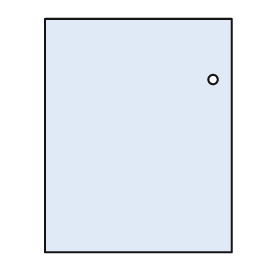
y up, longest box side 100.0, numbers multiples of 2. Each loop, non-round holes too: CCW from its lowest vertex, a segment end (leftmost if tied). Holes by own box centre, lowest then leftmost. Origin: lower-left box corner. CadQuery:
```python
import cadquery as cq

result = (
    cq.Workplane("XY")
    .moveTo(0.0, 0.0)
    .lineTo(80.0, 0.0)
    .lineTo(80.0, 100.0)
    .lineTo(0.0, 100.0)
    .close()
    .moveTo(72.0, 74.0)
    .circle(2.0)
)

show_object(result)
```